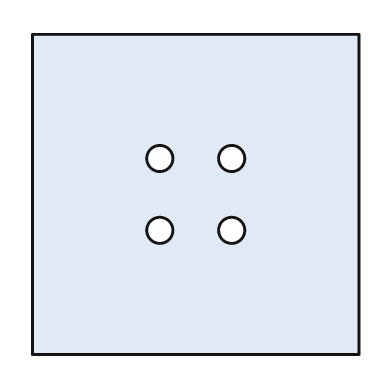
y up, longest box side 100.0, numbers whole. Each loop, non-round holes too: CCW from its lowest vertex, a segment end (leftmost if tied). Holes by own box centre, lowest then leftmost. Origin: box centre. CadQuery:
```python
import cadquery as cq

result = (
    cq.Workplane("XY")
    .moveTo(-50.0, -49.0)
    .lineTo(50.0, -49.0)
    .lineTo(50.0, 49.0)
    .lineTo(-50.0, 49.0)
    .close()
    .moveTo(-11.0, -11.0)
    .circle(4.0)
    .moveTo(11.0, -11.0)
    .circle(4.0)
    .moveTo(-11.0, 11.0)
    .circle(4.0)
    .moveTo(11.0, 11.0)
    .circle(4.0)
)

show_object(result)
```